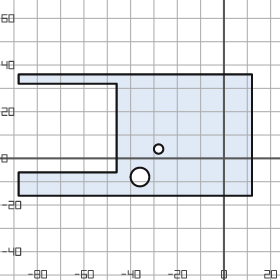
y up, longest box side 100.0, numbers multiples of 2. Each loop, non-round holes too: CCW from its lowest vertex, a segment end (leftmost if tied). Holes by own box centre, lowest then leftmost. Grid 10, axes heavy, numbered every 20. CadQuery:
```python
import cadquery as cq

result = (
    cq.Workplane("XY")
    .moveTo(-88.0, -16.0)
    .lineTo(12.0, -16.0)
    .lineTo(12.0, 36.0)
    .lineTo(-88.0, 36.0)
    .lineTo(-88.0, 32.0)
    .lineTo(-46.0, 32.0)
    .lineTo(-46.0, -6.0)
    .lineTo(-88.0, -6.0)
    .close()
    .moveTo(-36.0, -8.0)
    .circle(4.0)
    .moveTo(-28.0, 4.0)
    .circle(2.0)
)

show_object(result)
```